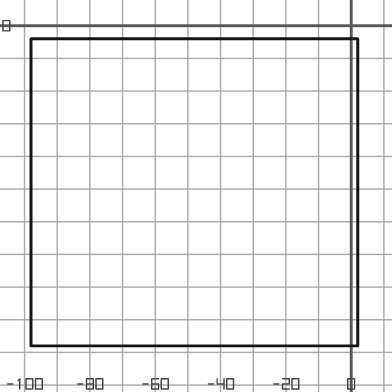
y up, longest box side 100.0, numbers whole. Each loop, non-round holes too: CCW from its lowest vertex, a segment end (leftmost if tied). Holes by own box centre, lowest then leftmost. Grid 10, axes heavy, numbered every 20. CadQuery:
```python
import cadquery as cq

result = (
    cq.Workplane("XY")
    .moveTo(-98.0, -98.0)
    .lineTo(2.0, -98.0)
    .lineTo(2.0, -4.0)
    .lineTo(-98.0, -4.0)
    .close()
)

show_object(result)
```